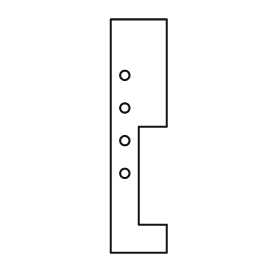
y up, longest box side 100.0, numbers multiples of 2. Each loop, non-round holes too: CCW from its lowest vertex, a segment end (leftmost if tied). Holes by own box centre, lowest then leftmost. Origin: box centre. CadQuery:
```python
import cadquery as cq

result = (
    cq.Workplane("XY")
    .moveTo(-12.0, -50.0)
    .lineTo(12.0, -50.0)
    .lineTo(12.0, -38.0)
    .lineTo(0.0, -38.0)
    .lineTo(0.0, 4.0)
    .lineTo(12.0, 4.0)
    .lineTo(12.0, 50.0)
    .lineTo(-12.0, 50.0)
    .close()
    .moveTo(-6.0, -16.0)
    .circle(2.0)
    .moveTo(-6.0, -2.0)
    .circle(2.0)
    .moveTo(-6.0, 12.0)
    .circle(2.0)
    .moveTo(-6.0, 26.0)
    .circle(2.0)
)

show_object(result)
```